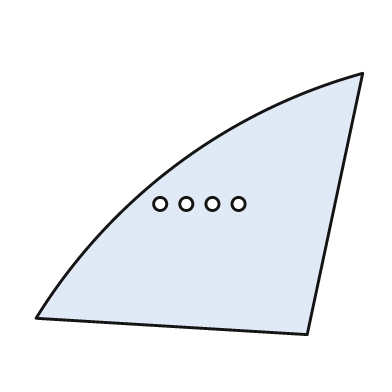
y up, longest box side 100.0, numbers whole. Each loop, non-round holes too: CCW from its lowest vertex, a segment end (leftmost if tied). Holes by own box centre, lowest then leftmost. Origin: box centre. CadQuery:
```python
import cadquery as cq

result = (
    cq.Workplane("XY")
    .moveTo(33.0, -40.0)
    .lineTo(50.0, 40.0)
    .threePointArc((-7.0, 12.0), (-50.0, -35.0))
    .close()
    .moveTo(-12.0, 0.0)
    .circle(2.0)
    .moveTo(-4.0, 0.0)
    .circle(2.0)
    .moveTo(4.0, 0.0)
    .circle(2.0)
    .moveTo(12.0, 0.0)
    .circle(2.0)
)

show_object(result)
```